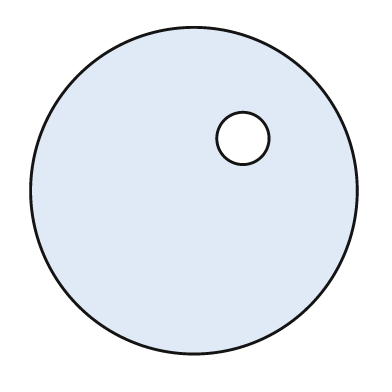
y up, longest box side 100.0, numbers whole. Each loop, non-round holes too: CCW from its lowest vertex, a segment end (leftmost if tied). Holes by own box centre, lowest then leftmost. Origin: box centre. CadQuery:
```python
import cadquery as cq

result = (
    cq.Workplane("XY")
    .moveTo(0.0, 0.0)
    .circle(50.0)
    .moveTo(15.0, 16.0)
    .circle(8.0)
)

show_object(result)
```